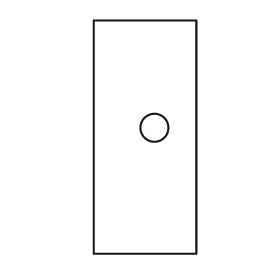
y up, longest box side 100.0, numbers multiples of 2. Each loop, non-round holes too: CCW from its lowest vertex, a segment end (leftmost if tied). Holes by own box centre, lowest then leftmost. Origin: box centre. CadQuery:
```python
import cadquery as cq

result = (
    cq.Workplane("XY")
    .moveTo(-22.0, -50.0)
    .lineTo(22.0, -50.0)
    .lineTo(22.0, 50.0)
    .lineTo(-22.0, 50.0)
    .close()
    .moveTo(4.0, 4.0)
    .circle(6.0)
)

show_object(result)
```